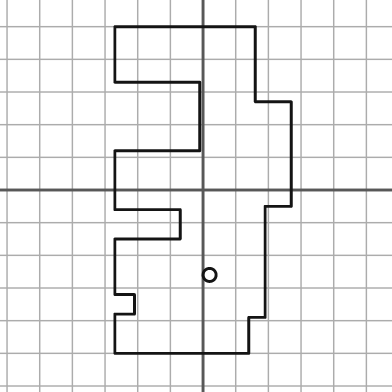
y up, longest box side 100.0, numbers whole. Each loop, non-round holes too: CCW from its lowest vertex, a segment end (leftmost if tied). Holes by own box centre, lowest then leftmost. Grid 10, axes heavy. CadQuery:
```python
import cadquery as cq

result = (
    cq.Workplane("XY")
    .moveTo(-27.0, -50.0)
    .lineTo(14.0, -50.0)
    .lineTo(14.0, -39.0)
    .lineTo(19.0, -39.0)
    .lineTo(19.0, -5.0)
    .lineTo(27.0, -5.0)
    .lineTo(27.0, 27.0)
    .lineTo(16.0, 27.0)
    .lineTo(16.0, 50.0)
    .lineTo(-27.0, 50.0)
    .lineTo(-27.0, 33.0)
    .lineTo(-1.0, 33.0)
    .lineTo(-1.0, 12.0)
    .lineTo(-27.0, 12.0)
    .lineTo(-27.0, -6.0)
    .lineTo(-7.0, -6.0)
    .lineTo(-7.0, -15.0)
    .lineTo(-27.0, -15.0)
    .lineTo(-27.0, -32.0)
    .lineTo(-21.0, -32.0)
    .lineTo(-21.0, -38.0)
    .lineTo(-27.0, -38.0)
    .close()
    .moveTo(2.0, -26.0)
    .circle(2.0)
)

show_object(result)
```